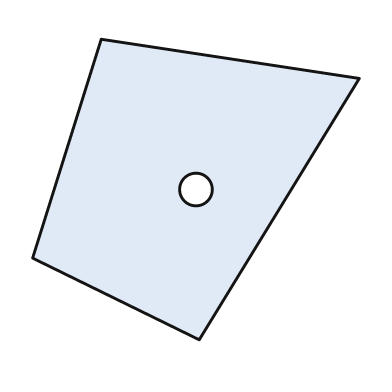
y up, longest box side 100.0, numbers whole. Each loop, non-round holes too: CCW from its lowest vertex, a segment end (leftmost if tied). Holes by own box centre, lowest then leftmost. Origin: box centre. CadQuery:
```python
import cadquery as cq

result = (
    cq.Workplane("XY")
    .moveTo(1.0, -46.0)
    .lineTo(50.0, 34.0)
    .lineTo(-29.0, 46.0)
    .lineTo(-50.0, -21.0)
    .close()
    .moveTo(0.0, 0.0)
    .circle(5.0)
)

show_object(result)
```